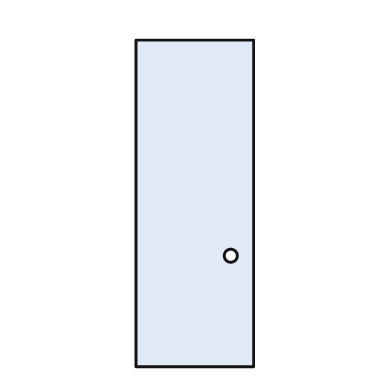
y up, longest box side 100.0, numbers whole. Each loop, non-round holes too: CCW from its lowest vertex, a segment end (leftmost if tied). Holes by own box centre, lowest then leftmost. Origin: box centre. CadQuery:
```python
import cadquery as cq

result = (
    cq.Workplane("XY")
    .moveTo(-18.0, -50.0)
    .lineTo(18.0, -50.0)
    .lineTo(18.0, 50.0)
    .lineTo(-18.0, 50.0)
    .close()
    .moveTo(11.0, -16.0)
    .circle(2.0)
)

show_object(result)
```